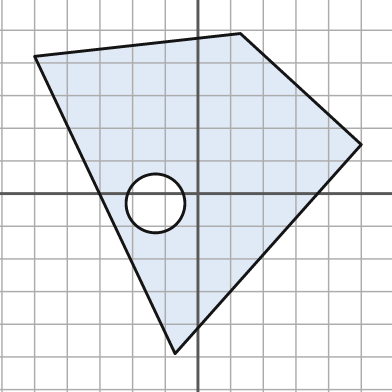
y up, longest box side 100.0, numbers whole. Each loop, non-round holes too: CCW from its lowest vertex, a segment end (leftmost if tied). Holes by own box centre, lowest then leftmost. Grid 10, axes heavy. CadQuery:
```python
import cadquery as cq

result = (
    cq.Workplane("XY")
    .moveTo(-7.0, -49.0)
    .lineTo(50.0, 15.0)
    .lineTo(13.0, 49.0)
    .lineTo(-50.0, 42.0)
    .close()
    .moveTo(-13.0, -3.0)
    .circle(9.0)
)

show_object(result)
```